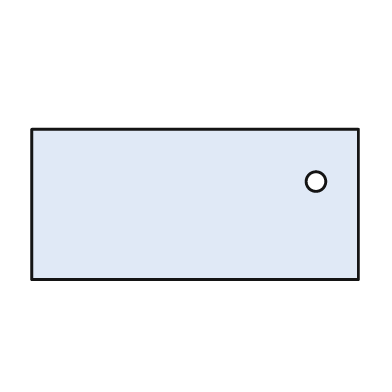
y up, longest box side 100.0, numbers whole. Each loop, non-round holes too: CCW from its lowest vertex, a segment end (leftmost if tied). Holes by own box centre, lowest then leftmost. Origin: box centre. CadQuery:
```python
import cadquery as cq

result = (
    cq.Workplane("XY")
    .moveTo(-50.0, -23.0)
    .lineTo(50.0, -23.0)
    .lineTo(50.0, 23.0)
    .lineTo(-50.0, 23.0)
    .close()
    .moveTo(37.0, 7.0)
    .circle(3.0)
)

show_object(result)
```